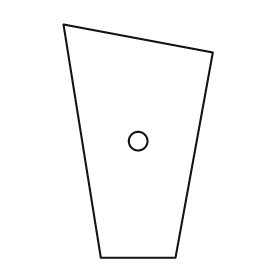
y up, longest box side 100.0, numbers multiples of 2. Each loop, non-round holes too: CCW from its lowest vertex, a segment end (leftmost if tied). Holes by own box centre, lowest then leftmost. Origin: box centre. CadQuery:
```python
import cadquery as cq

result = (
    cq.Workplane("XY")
    .moveTo(-16.0, -50.0)
    .lineTo(16.0, -50.0)
    .lineTo(32.0, 38.0)
    .lineTo(-32.0, 50.0)
    .close()
    .moveTo(0.0, 0.0)
    .circle(4.0)
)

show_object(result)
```